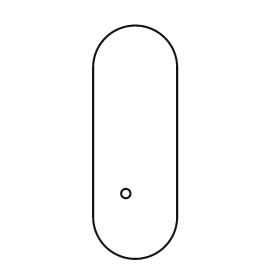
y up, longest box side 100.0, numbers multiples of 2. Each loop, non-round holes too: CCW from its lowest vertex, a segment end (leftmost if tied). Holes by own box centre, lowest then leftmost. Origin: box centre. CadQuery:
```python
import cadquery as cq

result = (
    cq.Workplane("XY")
    .moveTo(-18.0, -32.0)
    .threePointArc((0.0, -50.0), (18.0, -32.0))
    .lineTo(18.0, 32.0)
    .threePointArc((0.0, 50.0), (-18.0, 32.0))
    .close()
    .moveTo(-4.0, -22.0)
    .circle(2.0)
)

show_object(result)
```